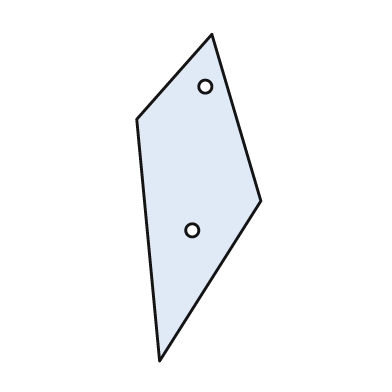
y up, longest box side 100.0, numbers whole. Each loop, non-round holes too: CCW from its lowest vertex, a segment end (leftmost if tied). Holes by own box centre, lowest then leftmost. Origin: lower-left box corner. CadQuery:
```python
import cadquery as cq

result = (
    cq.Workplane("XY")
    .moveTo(7.0, 0.0)
    .lineTo(38.0, 49.0)
    .lineTo(23.0, 100.0)
    .lineTo(0.0, 74.0)
    .close()
    .moveTo(17.0, 40.0)
    .circle(2.0)
    .moveTo(21.0, 84.0)
    .circle(2.0)
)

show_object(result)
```